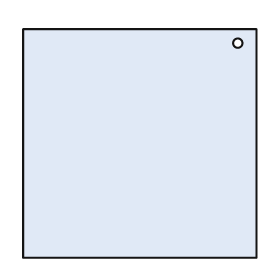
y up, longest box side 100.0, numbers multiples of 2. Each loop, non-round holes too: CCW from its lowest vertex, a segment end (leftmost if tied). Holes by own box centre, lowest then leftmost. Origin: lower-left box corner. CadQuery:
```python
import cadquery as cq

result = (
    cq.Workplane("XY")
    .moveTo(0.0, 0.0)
    .lineTo(100.0, 0.0)
    .lineTo(100.0, 98.0)
    .lineTo(0.0, 98.0)
    .close()
    .moveTo(92.0, 92.0)
    .circle(2.0)
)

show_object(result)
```